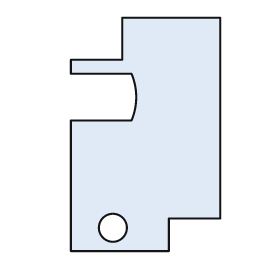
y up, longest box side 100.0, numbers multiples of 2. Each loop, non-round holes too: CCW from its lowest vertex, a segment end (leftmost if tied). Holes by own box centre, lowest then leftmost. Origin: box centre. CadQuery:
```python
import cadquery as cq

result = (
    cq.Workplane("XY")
    .moveTo(-32.0, -50.0)
    .lineTo(10.0, -50.0)
    .lineTo(10.0, -36.0)
    .lineTo(32.0, -36.0)
    .lineTo(32.0, 50.0)
    .lineTo(-10.0, 50.0)
    .lineTo(-10.0, 32.0)
    .lineTo(-32.0, 32.0)
    .lineTo(-32.0, 26.0)
    .lineTo(-6.0, 26.0)
    .threePointArc((-4.0, 16.0), (-6.0, 6.0))
    .lineTo(-32.0, 6.0)
    .close()
    .moveTo(-14.0, -40.0)
    .circle(6.0)
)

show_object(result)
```